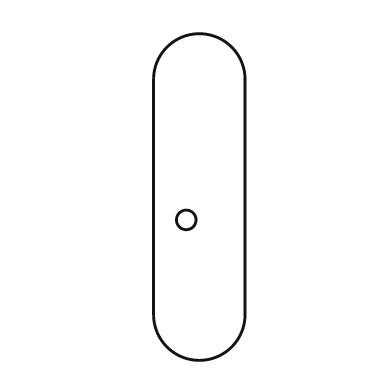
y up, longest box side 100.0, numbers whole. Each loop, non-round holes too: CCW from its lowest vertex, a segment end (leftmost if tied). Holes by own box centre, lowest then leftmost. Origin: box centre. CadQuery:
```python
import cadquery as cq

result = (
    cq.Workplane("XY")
    .moveTo(-14.0, -36.0)
    .threePointArc((0.0, -50.0), (14.0, -36.0))
    .lineTo(14.0, 36.0)
    .threePointArc((0.0, 50.0), (-14.0, 36.0))
    .close()
    .moveTo(-4.0, -7.0)
    .circle(3.0)
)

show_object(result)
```